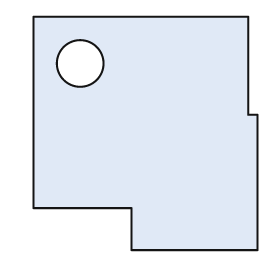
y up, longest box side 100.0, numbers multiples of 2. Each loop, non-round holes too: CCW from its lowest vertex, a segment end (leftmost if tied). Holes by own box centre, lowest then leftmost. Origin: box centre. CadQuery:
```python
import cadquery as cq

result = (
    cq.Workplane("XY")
    .moveTo(-6.0, -50.0)
    .lineTo(48.0, -50.0)
    .lineTo(48.0, 8.0)
    .lineTo(44.0, 8.0)
    .lineTo(44.0, 50.0)
    .lineTo(-48.0, 50.0)
    .lineTo(-48.0, -32.0)
    .lineTo(-6.0, -32.0)
    .close()
    .moveTo(-28.0, 30.0)
    .circle(10.0)
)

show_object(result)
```